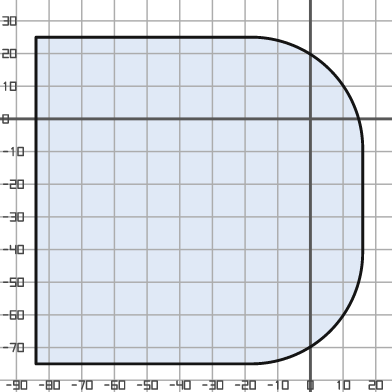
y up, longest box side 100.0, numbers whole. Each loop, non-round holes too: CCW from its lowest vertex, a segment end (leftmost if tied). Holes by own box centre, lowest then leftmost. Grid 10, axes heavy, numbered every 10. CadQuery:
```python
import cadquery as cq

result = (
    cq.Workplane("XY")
    .moveTo(-84.0, -75.0)
    .lineTo(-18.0, -75.0)
    .threePointArc((6.0, -65.0), (16.0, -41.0))
    .lineTo(16.0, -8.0)
    .threePointArc((6.0, 15.0), (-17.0, 25.0))
    .lineTo(-84.0, 25.0)
    .close()
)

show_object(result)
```